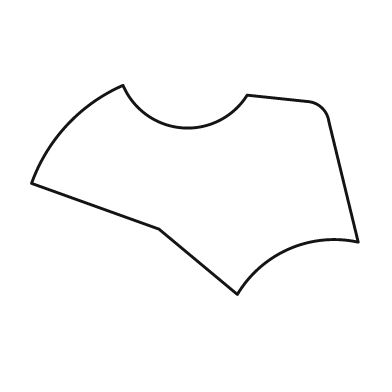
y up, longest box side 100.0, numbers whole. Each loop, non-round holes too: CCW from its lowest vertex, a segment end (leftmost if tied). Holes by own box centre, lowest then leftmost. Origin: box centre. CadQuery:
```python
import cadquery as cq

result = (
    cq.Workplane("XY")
    .moveTo(13.0, -32.0)
    .threePointArc((29.0, -18.0), (50.0, -16.0))
    .lineTo(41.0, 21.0)
    .threePointArc((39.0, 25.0), (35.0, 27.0))
    .lineTo(16.0, 29.0)
    .threePointArc((-4.0, 19.0), (-22.0, 32.0))
    .threePointArc((-39.0, 20.0), (-50.0, 2.0))
    .lineTo(-11.0, -12.0)
    .close()
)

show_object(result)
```